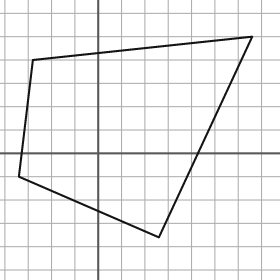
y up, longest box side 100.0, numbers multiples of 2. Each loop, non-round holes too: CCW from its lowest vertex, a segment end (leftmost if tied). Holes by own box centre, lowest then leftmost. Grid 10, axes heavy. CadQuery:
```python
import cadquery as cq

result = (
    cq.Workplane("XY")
    .moveTo(26.0, -36.0)
    .lineTo(66.0, 50.0)
    .lineTo(-28.0, 40.0)
    .lineTo(-34.0, -10.0)
    .close()
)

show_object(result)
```